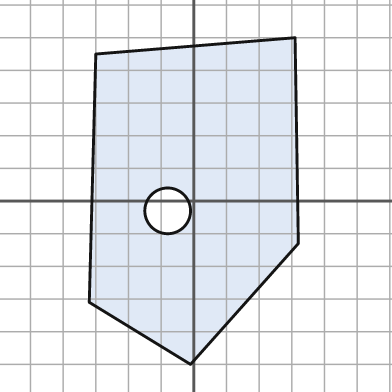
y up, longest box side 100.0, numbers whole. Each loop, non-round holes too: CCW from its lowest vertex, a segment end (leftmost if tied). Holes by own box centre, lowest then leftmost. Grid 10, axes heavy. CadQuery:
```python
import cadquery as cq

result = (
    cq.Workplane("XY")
    .moveTo(-1.0, -50.0)
    .lineTo(32.0, -13.0)
    .lineTo(31.0, 50.0)
    .lineTo(-30.0, 45.0)
    .lineTo(-32.0, -31.0)
    .close()
    .moveTo(-8.0, -3.0)
    .circle(7.0)
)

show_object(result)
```